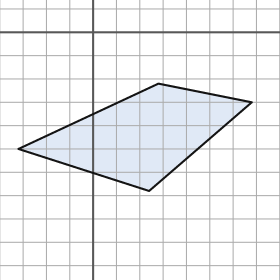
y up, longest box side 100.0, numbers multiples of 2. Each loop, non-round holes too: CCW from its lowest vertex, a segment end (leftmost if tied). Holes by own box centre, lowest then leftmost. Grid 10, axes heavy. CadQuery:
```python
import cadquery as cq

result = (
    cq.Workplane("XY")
    .moveTo(24.0, -68.0)
    .lineTo(68.0, -30.0)
    .lineTo(28.0, -22.0)
    .lineTo(-32.0, -50.0)
    .close()
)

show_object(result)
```